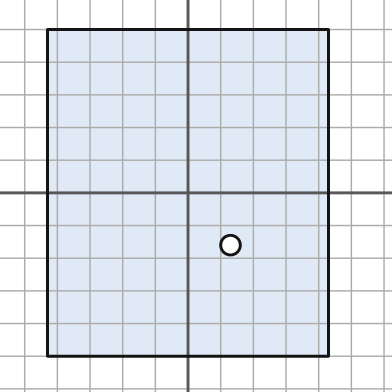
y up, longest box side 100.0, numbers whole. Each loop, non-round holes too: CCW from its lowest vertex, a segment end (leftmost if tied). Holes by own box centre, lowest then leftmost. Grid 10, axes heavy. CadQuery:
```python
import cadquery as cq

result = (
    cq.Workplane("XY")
    .moveTo(-43.0, -50.0)
    .lineTo(43.0, -50.0)
    .lineTo(43.0, 50.0)
    .lineTo(-43.0, 50.0)
    .close()
    .moveTo(13.0, -16.0)
    .circle(3.0)
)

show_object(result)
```